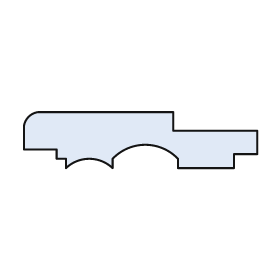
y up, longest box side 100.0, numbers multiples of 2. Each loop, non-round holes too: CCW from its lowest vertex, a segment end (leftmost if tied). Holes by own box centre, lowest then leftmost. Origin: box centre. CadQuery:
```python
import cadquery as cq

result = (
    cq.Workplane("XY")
    .moveTo(-32.0, -12.0)
    .threePointArc((-22.0, -8.0), (-12.0, -12.0))
    .lineTo(-12.0, -8.0)
    .threePointArc((2.0, -2.0), (16.0, -8.0))
    .lineTo(16.0, -12.0)
    .lineTo(40.0, -12.0)
    .lineTo(40.0, -6.0)
    .lineTo(50.0, -6.0)
    .lineTo(50.0, 4.0)
    .lineTo(14.0, 4.0)
    .lineTo(14.0, 12.0)
    .lineTo(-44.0, 12.0)
    .threePointArc((-48.0, 10.0), (-50.0, 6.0))
    .lineTo(-50.0, -4.0)
    .lineTo(-36.0, -4.0)
    .lineTo(-36.0, -8.0)
    .lineTo(-32.0, -8.0)
    .close()
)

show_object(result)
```